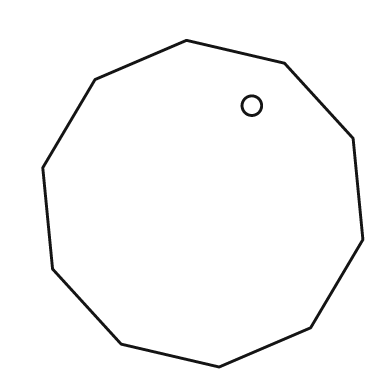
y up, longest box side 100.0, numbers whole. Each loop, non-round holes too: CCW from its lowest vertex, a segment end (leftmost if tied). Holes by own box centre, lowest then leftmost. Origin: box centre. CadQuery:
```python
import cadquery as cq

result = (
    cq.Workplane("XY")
    .moveTo(5.0, -50.0)
    .lineTo(33.0, -38.0)
    .lineTo(49.0, -11.0)
    .lineTo(46.0, 20.0)
    .lineTo(25.0, 43.0)
    .lineTo(-5.0, 50.0)
    .lineTo(-33.0, 38.0)
    .lineTo(-49.0, 11.0)
    .lineTo(-46.0, -20.0)
    .lineTo(-25.0, -43.0)
    .close()
    .moveTo(15.0, 30.0)
    .circle(3.0)
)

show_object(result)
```